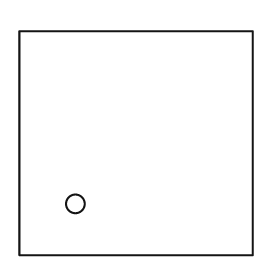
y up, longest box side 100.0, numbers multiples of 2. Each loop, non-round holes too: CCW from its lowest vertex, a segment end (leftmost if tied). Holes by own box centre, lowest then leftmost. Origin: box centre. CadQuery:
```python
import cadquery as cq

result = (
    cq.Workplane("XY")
    .moveTo(-50.0, -48.0)
    .lineTo(50.0, -48.0)
    .lineTo(50.0, 48.0)
    .lineTo(-50.0, 48.0)
    .close()
    .moveTo(-26.0, -26.0)
    .circle(4.0)
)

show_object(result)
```